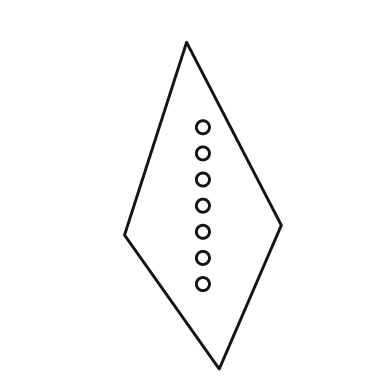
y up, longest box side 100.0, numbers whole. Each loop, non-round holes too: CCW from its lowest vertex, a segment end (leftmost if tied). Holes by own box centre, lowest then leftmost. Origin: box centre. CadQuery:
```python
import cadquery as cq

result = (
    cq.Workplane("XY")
    .moveTo(5.0, -50.0)
    .lineTo(24.0, -6.0)
    .lineTo(-5.0, 50.0)
    .lineTo(-24.0, -9.0)
    .close()
    .moveTo(0.0, -24.0)
    .circle(2.0)
    .moveTo(0.0, -16.0)
    .circle(2.0)
    .moveTo(0.0, -8.0)
    .circle(2.0)
    .moveTo(0.0, 0.0)
    .circle(2.0)
    .moveTo(0.0, 8.0)
    .circle(2.0)
    .moveTo(0.0, 16.0)
    .circle(2.0)
    .moveTo(0.0, 24.0)
    .circle(2.0)
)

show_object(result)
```